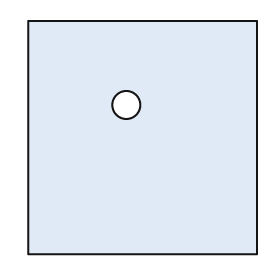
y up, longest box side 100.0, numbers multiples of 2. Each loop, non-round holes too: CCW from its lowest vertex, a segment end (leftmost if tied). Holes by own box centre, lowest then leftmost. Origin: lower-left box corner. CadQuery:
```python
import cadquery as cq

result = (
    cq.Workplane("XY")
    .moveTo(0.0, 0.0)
    .lineTo(98.0, 0.0)
    .lineTo(98.0, 100.0)
    .lineTo(0.0, 100.0)
    .close()
    .moveTo(42.0, 64.0)
    .circle(6.0)
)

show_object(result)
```